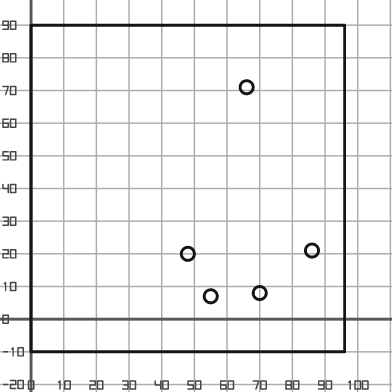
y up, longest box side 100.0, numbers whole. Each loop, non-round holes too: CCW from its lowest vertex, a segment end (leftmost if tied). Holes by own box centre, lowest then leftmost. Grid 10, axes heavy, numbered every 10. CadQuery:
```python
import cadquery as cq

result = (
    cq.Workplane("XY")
    .moveTo(0.0, -10.0)
    .lineTo(96.0, -10.0)
    .lineTo(96.0, 90.0)
    .lineTo(0.0, 90.0)
    .close()
    .moveTo(55.0, 7.0)
    .circle(2.0)
    .moveTo(70.0, 8.0)
    .circle(2.0)
    .moveTo(48.0, 20.0)
    .circle(2.0)
    .moveTo(86.0, 21.0)
    .circle(2.0)
    .moveTo(66.0, 71.0)
    .circle(2.0)
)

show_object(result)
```